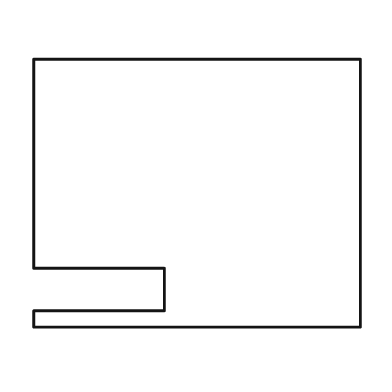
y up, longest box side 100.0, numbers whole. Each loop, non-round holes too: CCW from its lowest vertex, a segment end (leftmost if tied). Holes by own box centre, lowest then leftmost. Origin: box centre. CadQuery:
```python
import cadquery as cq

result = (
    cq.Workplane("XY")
    .moveTo(-50.0, -41.0)
    .lineTo(50.0, -41.0)
    .lineTo(50.0, 41.0)
    .lineTo(-50.0, 41.0)
    .lineTo(-50.0, -23.0)
    .lineTo(-10.0, -23.0)
    .lineTo(-10.0, -36.0)
    .lineTo(-50.0, -36.0)
    .close()
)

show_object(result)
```